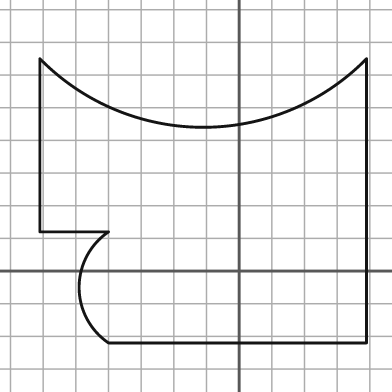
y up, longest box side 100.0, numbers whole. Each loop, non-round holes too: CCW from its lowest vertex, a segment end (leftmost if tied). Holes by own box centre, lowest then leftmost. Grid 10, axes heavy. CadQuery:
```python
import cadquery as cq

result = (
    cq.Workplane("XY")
    .moveTo(-40.0, -22.0)
    .lineTo(39.0, -22.0)
    .lineTo(39.0, 65.0)
    .threePointArc((-11.0, 44.0), (-61.0, 65.0))
    .lineTo(-61.0, 12.0)
    .lineTo(-40.0, 12.0)
    .threePointArc((-49.0, -5.0), (-40.0, -22.0))
    .close()
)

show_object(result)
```